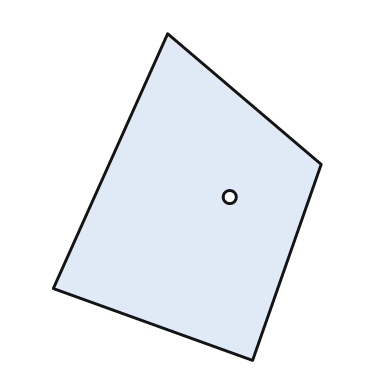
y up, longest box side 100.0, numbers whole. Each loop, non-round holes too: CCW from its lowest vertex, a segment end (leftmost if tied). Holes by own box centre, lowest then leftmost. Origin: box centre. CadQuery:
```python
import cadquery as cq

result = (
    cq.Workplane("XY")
    .moveTo(20.0, -50.0)
    .lineTo(41.0, 10.0)
    .lineTo(-6.0, 50.0)
    .lineTo(-41.0, -28.0)
    .close()
    .moveTo(13.0, 0.0)
    .circle(2.0)
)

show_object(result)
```